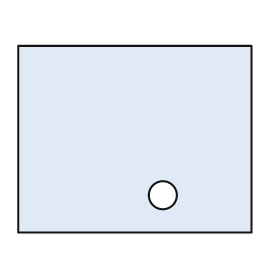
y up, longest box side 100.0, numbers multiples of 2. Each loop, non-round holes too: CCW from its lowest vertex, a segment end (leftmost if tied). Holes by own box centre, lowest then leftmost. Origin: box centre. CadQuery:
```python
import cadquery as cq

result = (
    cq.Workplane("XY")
    .moveTo(-50.0, -40.0)
    .lineTo(50.0, -40.0)
    .lineTo(50.0, 40.0)
    .lineTo(-50.0, 40.0)
    .close()
    .moveTo(12.0, -24.0)
    .circle(6.0)
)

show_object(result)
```